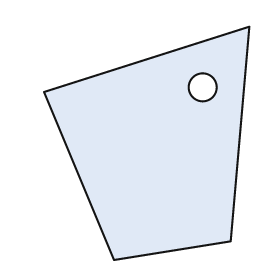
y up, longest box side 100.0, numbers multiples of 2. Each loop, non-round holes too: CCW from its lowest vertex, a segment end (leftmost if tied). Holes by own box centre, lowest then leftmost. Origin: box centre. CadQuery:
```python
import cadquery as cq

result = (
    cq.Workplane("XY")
    .moveTo(-14.0, -50.0)
    .lineTo(36.0, -42.0)
    .lineTo(44.0, 50.0)
    .lineTo(-44.0, 22.0)
    .close()
    .moveTo(24.0, 24.0)
    .circle(6.0)
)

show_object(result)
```